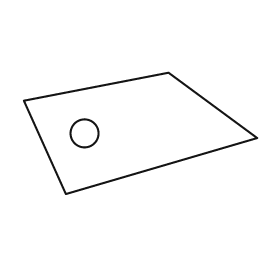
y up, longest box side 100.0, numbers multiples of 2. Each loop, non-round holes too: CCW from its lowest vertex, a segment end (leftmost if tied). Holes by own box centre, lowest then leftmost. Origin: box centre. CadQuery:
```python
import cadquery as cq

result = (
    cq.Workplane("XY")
    .moveTo(-32.0, -26.0)
    .lineTo(50.0, -2.0)
    .lineTo(12.0, 26.0)
    .lineTo(-50.0, 14.0)
    .close()
    .moveTo(-24.0, 0.0)
    .circle(6.0)
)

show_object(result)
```